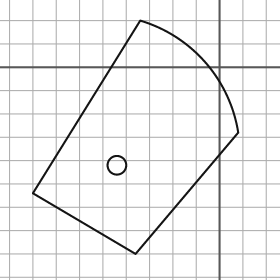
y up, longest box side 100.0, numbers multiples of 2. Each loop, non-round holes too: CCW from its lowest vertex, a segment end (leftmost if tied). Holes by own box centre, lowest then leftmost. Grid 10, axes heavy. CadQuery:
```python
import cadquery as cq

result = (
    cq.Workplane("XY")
    .moveTo(-36.0, -80.0)
    .lineTo(8.0, -28.0)
    .threePointArc((-6.0, 2.0), (-34.0, 20.0))
    .lineTo(-80.0, -54.0)
    .close()
    .moveTo(-44.0, -42.0)
    .circle(4.0)
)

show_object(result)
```